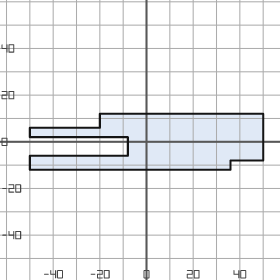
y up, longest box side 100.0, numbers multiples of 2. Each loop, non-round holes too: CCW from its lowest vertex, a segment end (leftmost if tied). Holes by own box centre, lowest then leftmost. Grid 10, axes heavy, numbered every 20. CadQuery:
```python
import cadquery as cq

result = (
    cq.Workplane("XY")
    .moveTo(-50.0, -12.0)
    .lineTo(36.0, -12.0)
    .lineTo(36.0, -8.0)
    .lineTo(50.0, -8.0)
    .lineTo(50.0, 12.0)
    .lineTo(-20.0, 12.0)
    .lineTo(-20.0, 6.0)
    .lineTo(-50.0, 6.0)
    .lineTo(-50.0, 2.0)
    .lineTo(-8.0, 2.0)
    .lineTo(-8.0, -6.0)
    .lineTo(-50.0, -6.0)
    .close()
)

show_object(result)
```